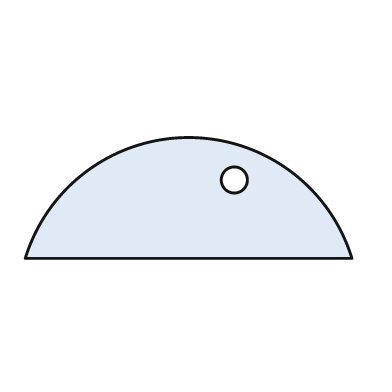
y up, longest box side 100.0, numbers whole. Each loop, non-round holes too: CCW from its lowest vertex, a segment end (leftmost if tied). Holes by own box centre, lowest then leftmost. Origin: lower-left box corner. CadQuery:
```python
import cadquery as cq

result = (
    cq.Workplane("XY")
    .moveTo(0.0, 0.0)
    .lineTo(100.0, 0.0)
    .threePointArc((50.0, 37.0), (0.0, 0.0))
    .close()
    .moveTo(64.0, 24.0)
    .circle(4.0)
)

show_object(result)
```